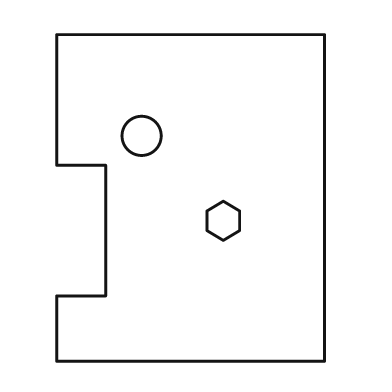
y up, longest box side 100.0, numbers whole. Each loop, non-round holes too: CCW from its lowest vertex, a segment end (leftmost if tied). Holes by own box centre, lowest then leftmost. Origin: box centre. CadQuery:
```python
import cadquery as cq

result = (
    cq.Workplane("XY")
    .moveTo(-41.0, -50.0)
    .lineTo(41.0, -50.0)
    .lineTo(41.0, 50.0)
    .lineTo(-41.0, 50.0)
    .lineTo(-41.0, 10.0)
    .lineTo(-26.0, 10.0)
    .lineTo(-26.0, -30.0)
    .lineTo(-41.0, -30.0)
    .close()
    .moveTo(10.0, -13.0)
    .lineTo(15.0, -10.0)
    .lineTo(15.0, -4.0)
    .lineTo(10.0, -1.0)
    .lineTo(5.0, -4.0)
    .lineTo(5.0, -10.0)
    .close()
    .moveTo(-15.0, 19.0)
    .circle(6.0)
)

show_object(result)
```